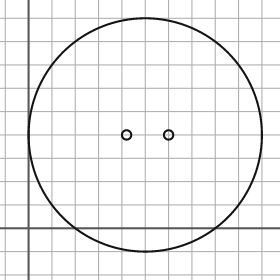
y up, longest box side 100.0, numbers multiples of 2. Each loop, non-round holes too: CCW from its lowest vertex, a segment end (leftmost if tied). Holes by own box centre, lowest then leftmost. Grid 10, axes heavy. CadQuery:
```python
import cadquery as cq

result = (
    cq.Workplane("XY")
    .moveTo(50.0, 40.0)
    .circle(50.0)
    .moveTo(42.0, 40.0)
    .circle(2.0)
    .moveTo(60.0, 40.0)
    .circle(2.0)
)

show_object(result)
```